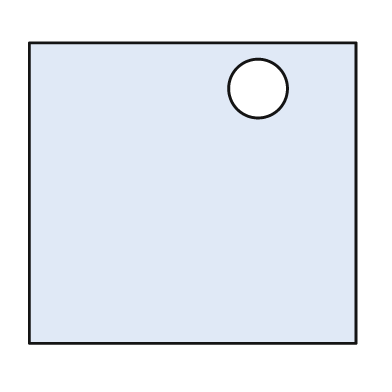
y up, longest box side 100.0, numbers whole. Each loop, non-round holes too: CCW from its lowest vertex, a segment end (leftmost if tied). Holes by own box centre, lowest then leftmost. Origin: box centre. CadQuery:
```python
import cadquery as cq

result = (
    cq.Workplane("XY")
    .moveTo(-50.0, -46.0)
    .lineTo(50.0, -46.0)
    .lineTo(50.0, 46.0)
    .lineTo(-50.0, 46.0)
    .close()
    .moveTo(20.0, 32.0)
    .circle(9.0)
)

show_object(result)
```